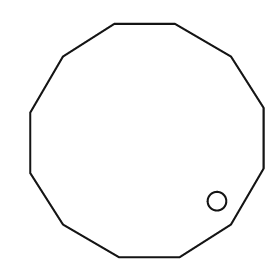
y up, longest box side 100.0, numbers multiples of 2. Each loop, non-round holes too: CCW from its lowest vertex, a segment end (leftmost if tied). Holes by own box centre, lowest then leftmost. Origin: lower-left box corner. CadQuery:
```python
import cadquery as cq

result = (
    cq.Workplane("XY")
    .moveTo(38.0, 0.0)
    .lineTo(64.0, 0.0)
    .lineTo(86.0, 14.0)
    .lineTo(100.0, 38.0)
    .lineTo(100.0, 64.0)
    .lineTo(86.0, 86.0)
    .lineTo(62.0, 100.0)
    .lineTo(36.0, 100.0)
    .lineTo(14.0, 86.0)
    .lineTo(0.0, 62.0)
    .lineTo(0.0, 36.0)
    .lineTo(14.0, 14.0)
    .close()
    .moveTo(80.0, 24.0)
    .circle(4.0)
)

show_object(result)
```